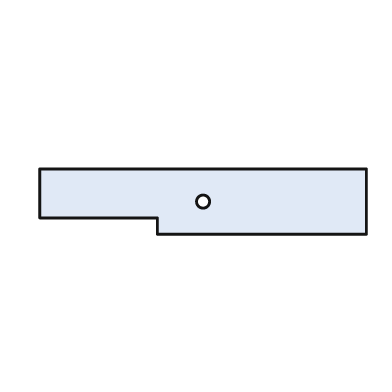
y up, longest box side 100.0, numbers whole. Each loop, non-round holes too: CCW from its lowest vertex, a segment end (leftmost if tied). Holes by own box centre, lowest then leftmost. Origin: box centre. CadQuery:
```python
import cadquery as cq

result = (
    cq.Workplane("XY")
    .moveTo(-14.0, -10.0)
    .lineTo(50.0, -10.0)
    .lineTo(50.0, 10.0)
    .lineTo(-50.0, 10.0)
    .lineTo(-50.0, -5.0)
    .lineTo(-14.0, -5.0)
    .close()
    .moveTo(0.0, 0.0)
    .circle(2.0)
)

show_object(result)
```